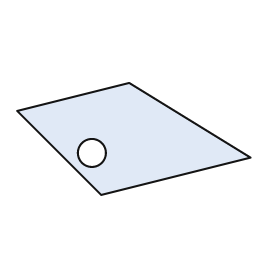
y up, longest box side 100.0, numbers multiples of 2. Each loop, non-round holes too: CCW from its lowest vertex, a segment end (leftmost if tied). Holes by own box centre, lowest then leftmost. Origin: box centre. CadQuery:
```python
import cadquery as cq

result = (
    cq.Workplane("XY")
    .moveTo(-14.0, -24.0)
    .lineTo(50.0, -8.0)
    .lineTo(-2.0, 24.0)
    .lineTo(-50.0, 12.0)
    .close()
    .moveTo(-18.0, -6.0)
    .circle(6.0)
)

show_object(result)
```